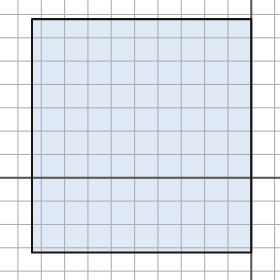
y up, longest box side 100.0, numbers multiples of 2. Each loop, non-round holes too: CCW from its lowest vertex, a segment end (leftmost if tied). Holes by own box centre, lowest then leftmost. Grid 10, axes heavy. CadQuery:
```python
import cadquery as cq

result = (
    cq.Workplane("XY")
    .moveTo(-94.0, -32.0)
    .lineTo(0.0, -32.0)
    .lineTo(0.0, 68.0)
    .lineTo(-94.0, 68.0)
    .close()
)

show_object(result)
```